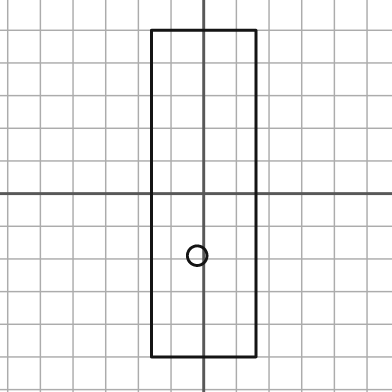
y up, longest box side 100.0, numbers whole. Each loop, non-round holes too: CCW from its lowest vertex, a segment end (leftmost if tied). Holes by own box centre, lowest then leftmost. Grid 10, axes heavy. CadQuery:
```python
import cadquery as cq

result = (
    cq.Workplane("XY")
    .moveTo(-16.0, -50.0)
    .lineTo(16.0, -50.0)
    .lineTo(16.0, 50.0)
    .lineTo(-16.0, 50.0)
    .close()
    .moveTo(-2.0, -19.0)
    .circle(3.0)
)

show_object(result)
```